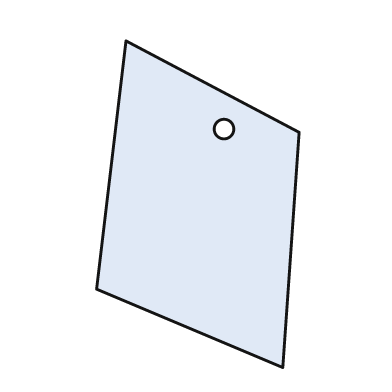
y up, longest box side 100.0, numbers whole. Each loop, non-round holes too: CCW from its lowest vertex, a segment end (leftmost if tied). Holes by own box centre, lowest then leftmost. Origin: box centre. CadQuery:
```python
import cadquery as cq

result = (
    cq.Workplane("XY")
    .moveTo(26.0, -50.0)
    .lineTo(31.0, 22.0)
    .lineTo(-22.0, 50.0)
    .lineTo(-31.0, -26.0)
    .close()
    .moveTo(8.0, 23.0)
    .circle(3.0)
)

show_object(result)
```